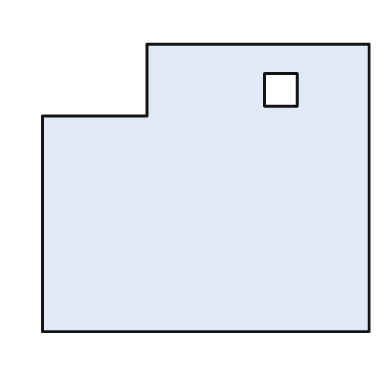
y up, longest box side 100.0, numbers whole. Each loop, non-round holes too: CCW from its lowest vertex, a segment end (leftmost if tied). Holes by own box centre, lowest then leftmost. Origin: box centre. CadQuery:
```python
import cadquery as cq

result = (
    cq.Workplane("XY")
    .moveTo(-50.0, -44.0)
    .lineTo(50.0, -44.0)
    .lineTo(50.0, 44.0)
    .lineTo(-18.0, 44.0)
    .lineTo(-18.0, 22.0)
    .lineTo(-50.0, 22.0)
    .close()
    .moveTo(18.0, 25.0)
    .lineTo(28.0, 25.0)
    .lineTo(28.0, 35.0)
    .lineTo(18.0, 35.0)
    .close()
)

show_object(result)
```